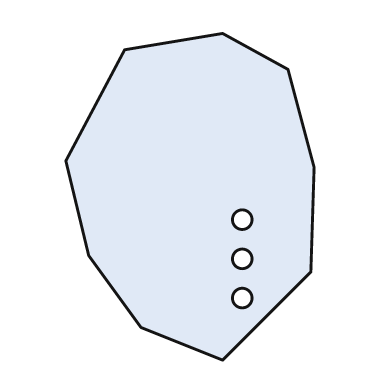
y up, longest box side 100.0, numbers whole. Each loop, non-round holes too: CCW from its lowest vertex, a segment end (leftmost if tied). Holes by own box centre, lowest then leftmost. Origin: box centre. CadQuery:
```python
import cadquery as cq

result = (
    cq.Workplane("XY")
    .moveTo(10.0, -50.0)
    .lineTo(37.0, -23.0)
    .lineTo(38.0, 9.0)
    .lineTo(30.0, 39.0)
    .lineTo(10.0, 50.0)
    .lineTo(-20.0, 45.0)
    .lineTo(-38.0, 11.0)
    .lineTo(-31.0, -18.0)
    .lineTo(-15.0, -40.0)
    .close()
    .moveTo(16.0, -31.0)
    .circle(3.0)
    .moveTo(16.0, -19.0)
    .circle(3.0)
    .moveTo(16.0, -7.0)
    .circle(3.0)
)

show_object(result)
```